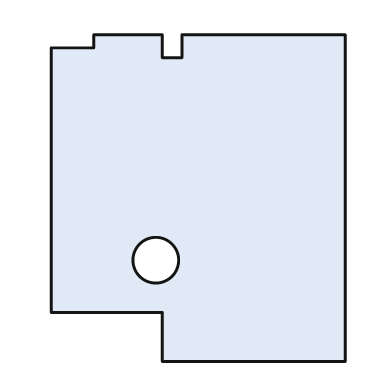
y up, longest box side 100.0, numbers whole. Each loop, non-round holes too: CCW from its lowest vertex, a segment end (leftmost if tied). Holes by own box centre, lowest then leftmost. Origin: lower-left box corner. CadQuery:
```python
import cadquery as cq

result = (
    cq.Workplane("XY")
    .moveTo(34.0, 0.0)
    .lineTo(90.0, 0.0)
    .lineTo(90.0, 100.0)
    .lineTo(40.0, 100.0)
    .lineTo(40.0, 93.0)
    .lineTo(34.0, 93.0)
    .lineTo(34.0, 100.0)
    .lineTo(13.0, 100.0)
    .lineTo(13.0, 96.0)
    .lineTo(0.0, 96.0)
    .lineTo(0.0, 15.0)
    .lineTo(34.0, 15.0)
    .close()
    .moveTo(32.0, 31.0)
    .circle(7.0)
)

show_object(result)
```